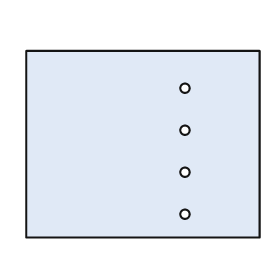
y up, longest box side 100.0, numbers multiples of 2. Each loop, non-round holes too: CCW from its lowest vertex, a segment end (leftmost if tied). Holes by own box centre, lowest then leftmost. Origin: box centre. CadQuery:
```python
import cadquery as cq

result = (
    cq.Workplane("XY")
    .moveTo(-50.0, -40.0)
    .lineTo(50.0, -40.0)
    .lineTo(50.0, 40.0)
    .lineTo(-50.0, 40.0)
    .close()
    .moveTo(18.0, -30.0)
    .circle(2.0)
    .moveTo(18.0, -12.0)
    .circle(2.0)
    .moveTo(18.0, 6.0)
    .circle(2.0)
    .moveTo(18.0, 24.0)
    .circle(2.0)
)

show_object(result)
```